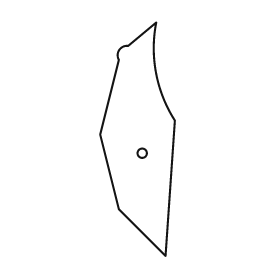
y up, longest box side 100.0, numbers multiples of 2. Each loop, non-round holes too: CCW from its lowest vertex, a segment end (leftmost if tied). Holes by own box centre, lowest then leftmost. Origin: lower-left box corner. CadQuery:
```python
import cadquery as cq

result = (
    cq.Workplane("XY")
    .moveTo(28.0, 0.0)
    .lineTo(32.0, 58.0)
    .threePointArc((24.0, 78.0), (24.0, 100.0))
    .lineTo(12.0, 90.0)
    .threePointArc((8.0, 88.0), (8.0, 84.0))
    .lineTo(0.0, 52.0)
    .lineTo(8.0, 20.0)
    .close()
    .moveTo(18.0, 44.0)
    .circle(2.0)
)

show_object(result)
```